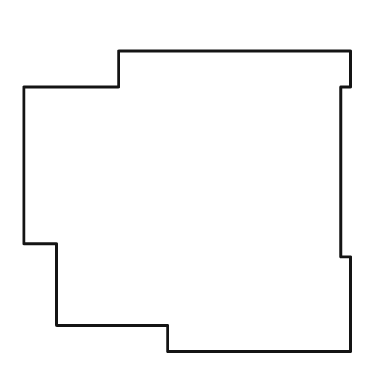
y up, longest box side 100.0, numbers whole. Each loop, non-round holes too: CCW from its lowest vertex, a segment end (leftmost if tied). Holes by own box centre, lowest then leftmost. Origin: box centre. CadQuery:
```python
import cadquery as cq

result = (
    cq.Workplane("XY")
    .moveTo(-6.0, -46.0)
    .lineTo(50.0, -46.0)
    .lineTo(50.0, -17.0)
    .lineTo(47.0, -17.0)
    .lineTo(47.0, 35.0)
    .lineTo(50.0, 35.0)
    .lineTo(50.0, 46.0)
    .lineTo(-21.0, 46.0)
    .lineTo(-21.0, 35.0)
    .lineTo(-50.0, 35.0)
    .lineTo(-50.0, -13.0)
    .lineTo(-40.0, -13.0)
    .lineTo(-40.0, -38.0)
    .lineTo(-6.0, -38.0)
    .close()
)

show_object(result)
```